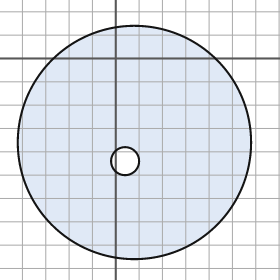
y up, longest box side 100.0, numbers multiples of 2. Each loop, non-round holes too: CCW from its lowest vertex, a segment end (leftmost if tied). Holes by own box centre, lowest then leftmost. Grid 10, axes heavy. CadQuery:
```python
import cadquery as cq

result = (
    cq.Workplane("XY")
    .moveTo(8.0, -36.0)
    .circle(50.0)
    .moveTo(4.0, -44.0)
    .circle(6.0)
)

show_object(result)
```